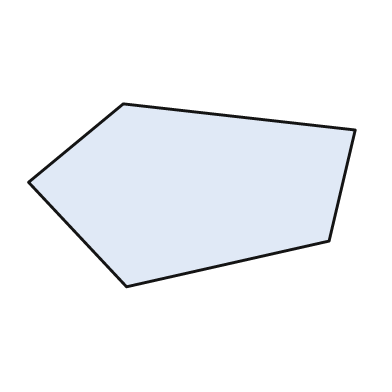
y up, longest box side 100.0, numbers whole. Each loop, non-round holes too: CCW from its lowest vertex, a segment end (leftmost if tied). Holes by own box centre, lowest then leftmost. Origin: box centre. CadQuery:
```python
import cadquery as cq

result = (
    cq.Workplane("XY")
    .moveTo(-20.0, -28.0)
    .lineTo(42.0, -14.0)
    .lineTo(50.0, 20.0)
    .lineTo(-21.0, 28.0)
    .lineTo(-50.0, 4.0)
    .close()
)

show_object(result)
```